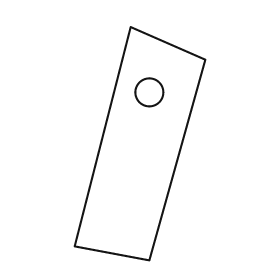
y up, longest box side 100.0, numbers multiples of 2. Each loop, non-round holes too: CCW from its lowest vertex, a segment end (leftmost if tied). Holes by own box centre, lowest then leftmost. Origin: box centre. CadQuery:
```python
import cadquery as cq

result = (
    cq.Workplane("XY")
    .moveTo(4.0, -50.0)
    .lineTo(28.0, 36.0)
    .lineTo(-4.0, 50.0)
    .lineTo(-28.0, -44.0)
    .close()
    .moveTo(4.0, 22.0)
    .circle(6.0)
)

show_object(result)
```